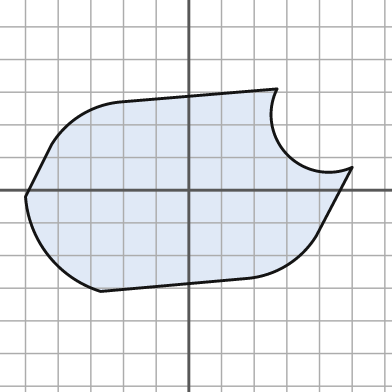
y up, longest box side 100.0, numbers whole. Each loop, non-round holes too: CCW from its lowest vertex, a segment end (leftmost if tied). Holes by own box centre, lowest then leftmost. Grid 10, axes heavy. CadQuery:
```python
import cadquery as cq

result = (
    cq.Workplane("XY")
    .moveTo(-27.0, -31.0)
    .lineTo(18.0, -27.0)
    .threePointArc((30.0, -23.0), (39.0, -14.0))
    .lineTo(50.0, 7.0)
    .threePointArc((30.0, 11.0), (27.0, 31.0))
    .lineTo(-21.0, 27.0)
    .threePointArc((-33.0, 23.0), (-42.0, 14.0))
    .lineTo(-50.0, -2.0)
    .threePointArc((-43.0, -20.0), (-27.0, -31.0))
    .close()
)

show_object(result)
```